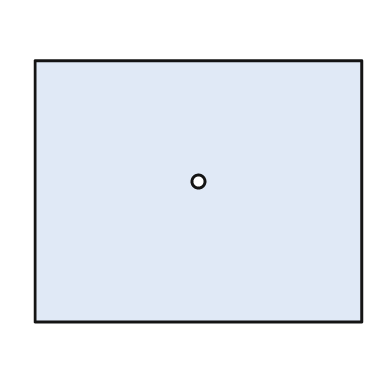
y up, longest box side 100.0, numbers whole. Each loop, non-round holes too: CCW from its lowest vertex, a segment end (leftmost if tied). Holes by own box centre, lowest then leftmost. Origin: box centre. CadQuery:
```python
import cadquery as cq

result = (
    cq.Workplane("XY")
    .moveTo(-50.0, -40.0)
    .lineTo(50.0, -40.0)
    .lineTo(50.0, 40.0)
    .lineTo(-50.0, 40.0)
    .close()
    .moveTo(0.0, 3.0)
    .circle(2.0)
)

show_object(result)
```